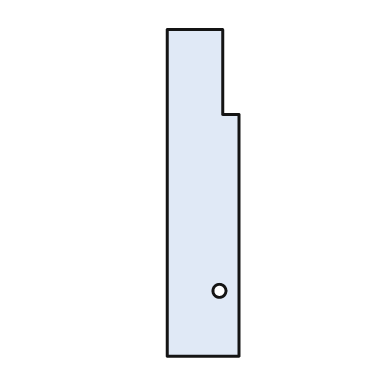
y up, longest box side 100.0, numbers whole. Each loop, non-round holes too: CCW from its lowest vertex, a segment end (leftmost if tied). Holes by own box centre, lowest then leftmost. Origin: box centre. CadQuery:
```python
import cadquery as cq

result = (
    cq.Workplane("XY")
    .moveTo(-11.0, -50.0)
    .lineTo(11.0, -50.0)
    .lineTo(11.0, 24.0)
    .lineTo(6.0, 24.0)
    .lineTo(6.0, 50.0)
    .lineTo(-11.0, 50.0)
    .close()
    .moveTo(5.0, -30.0)
    .circle(2.0)
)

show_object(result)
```